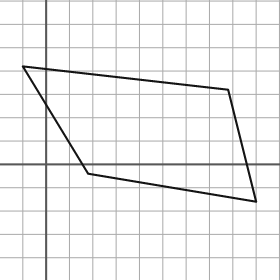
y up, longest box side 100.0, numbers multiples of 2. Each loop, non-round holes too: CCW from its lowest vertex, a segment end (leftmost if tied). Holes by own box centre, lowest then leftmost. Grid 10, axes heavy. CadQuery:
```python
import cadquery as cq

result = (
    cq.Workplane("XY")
    .moveTo(90.0, -16.0)
    .lineTo(78.0, 32.0)
    .lineTo(-10.0, 42.0)
    .lineTo(18.0, -4.0)
    .close()
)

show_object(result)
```